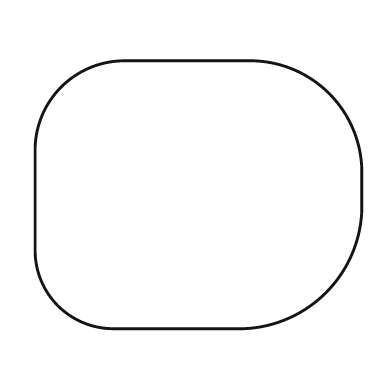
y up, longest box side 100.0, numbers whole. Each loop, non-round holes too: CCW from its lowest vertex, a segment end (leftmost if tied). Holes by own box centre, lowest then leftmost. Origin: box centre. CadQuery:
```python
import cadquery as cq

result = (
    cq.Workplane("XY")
    .moveTo(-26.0, -41.0)
    .lineTo(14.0, -41.0)
    .threePointArc((39.0, -30.0), (50.0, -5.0))
    .lineTo(50.0, 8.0)
    .threePointArc((40.0, 31.0), (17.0, 41.0))
    .lineTo(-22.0, 41.0)
    .threePointArc((-42.0, 33.0), (-50.0, 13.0))
    .lineTo(-50.0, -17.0)
    .threePointArc((-43.0, -34.0), (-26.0, -41.0))
    .close()
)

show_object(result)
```